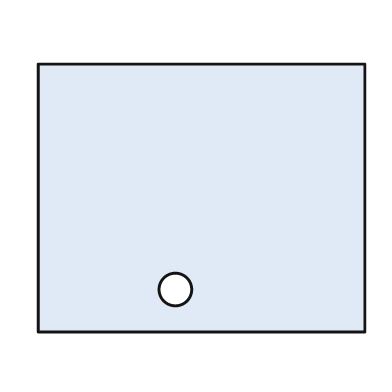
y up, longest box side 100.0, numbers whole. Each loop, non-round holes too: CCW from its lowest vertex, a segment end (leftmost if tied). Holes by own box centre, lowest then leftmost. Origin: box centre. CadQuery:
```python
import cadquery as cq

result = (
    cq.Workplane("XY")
    .moveTo(-50.0, -41.0)
    .lineTo(50.0, -41.0)
    .lineTo(50.0, 41.0)
    .lineTo(-50.0, 41.0)
    .close()
    .moveTo(-8.0, -28.0)
    .circle(5.0)
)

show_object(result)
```